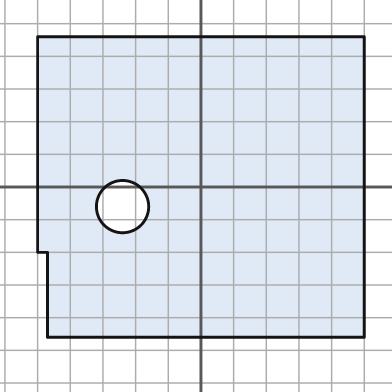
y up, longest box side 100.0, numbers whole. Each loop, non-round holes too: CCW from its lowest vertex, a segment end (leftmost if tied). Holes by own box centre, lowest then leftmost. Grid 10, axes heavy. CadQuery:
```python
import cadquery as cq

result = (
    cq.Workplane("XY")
    .moveTo(-47.0, -46.0)
    .lineTo(50.0, -46.0)
    .lineTo(50.0, 46.0)
    .lineTo(-50.0, 46.0)
    .lineTo(-50.0, -20.0)
    .lineTo(-47.0, -20.0)
    .close()
    .moveTo(-24.0, -6.0)
    .circle(8.0)
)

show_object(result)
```